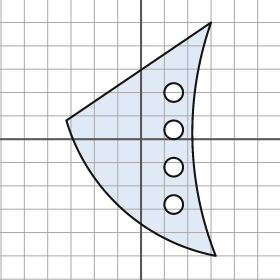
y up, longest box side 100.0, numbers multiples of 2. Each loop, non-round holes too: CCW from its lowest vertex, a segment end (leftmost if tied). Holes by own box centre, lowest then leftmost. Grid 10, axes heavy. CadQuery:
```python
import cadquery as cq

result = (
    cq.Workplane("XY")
    .moveTo(32.0, -50.0)
    .threePointArc((22.0, 0.0), (30.0, 50.0))
    .lineTo(-32.0, 8.0)
    .threePointArc((-8.0, -30.0), (32.0, -50.0))
    .close()
    .moveTo(14.0, -28.0)
    .circle(4.0)
    .moveTo(14.0, -12.0)
    .circle(4.0)
    .moveTo(14.0, 4.0)
    .circle(4.0)
    .moveTo(14.0, 20.0)
    .circle(4.0)
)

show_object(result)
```